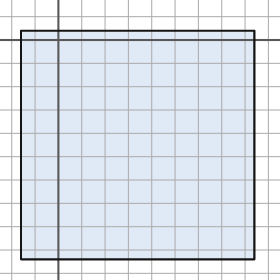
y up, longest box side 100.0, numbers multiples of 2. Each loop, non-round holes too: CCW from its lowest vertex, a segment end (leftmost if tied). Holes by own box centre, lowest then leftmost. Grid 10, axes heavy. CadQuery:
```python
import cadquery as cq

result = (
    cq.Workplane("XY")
    .moveTo(-16.0, -94.0)
    .lineTo(84.0, -94.0)
    .lineTo(84.0, 4.0)
    .lineTo(-16.0, 4.0)
    .close()
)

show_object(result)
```